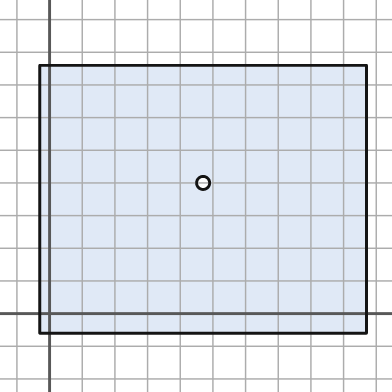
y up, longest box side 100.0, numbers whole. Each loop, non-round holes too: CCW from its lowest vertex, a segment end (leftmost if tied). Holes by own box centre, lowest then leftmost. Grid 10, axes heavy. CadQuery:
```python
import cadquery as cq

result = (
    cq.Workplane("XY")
    .moveTo(-3.0, -6.0)
    .lineTo(97.0, -6.0)
    .lineTo(97.0, 76.0)
    .lineTo(-3.0, 76.0)
    .close()
    .moveTo(47.0, 40.0)
    .circle(2.0)
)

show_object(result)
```